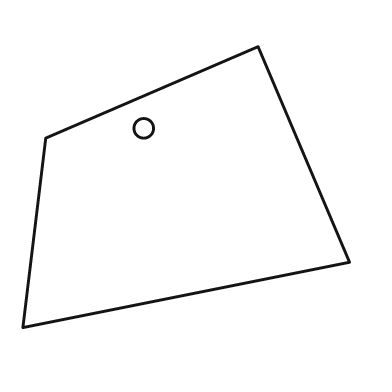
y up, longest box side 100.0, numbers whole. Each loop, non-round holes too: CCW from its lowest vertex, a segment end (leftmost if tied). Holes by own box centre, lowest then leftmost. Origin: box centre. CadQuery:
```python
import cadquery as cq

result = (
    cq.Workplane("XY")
    .moveTo(-50.0, -43.0)
    .lineTo(50.0, -23.0)
    .lineTo(22.0, 43.0)
    .lineTo(-43.0, 15.0)
    .close()
    .moveTo(-13.0, 18.0)
    .circle(3.0)
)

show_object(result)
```